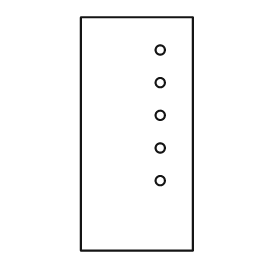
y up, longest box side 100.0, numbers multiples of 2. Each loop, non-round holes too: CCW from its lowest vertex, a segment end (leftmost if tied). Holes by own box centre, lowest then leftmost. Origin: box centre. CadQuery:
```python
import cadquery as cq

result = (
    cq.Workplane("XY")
    .moveTo(-24.0, -50.0)
    .lineTo(24.0, -50.0)
    .lineTo(24.0, 50.0)
    .lineTo(-24.0, 50.0)
    .close()
    .moveTo(10.0, -20.0)
    .circle(2.0)
    .moveTo(10.0, -6.0)
    .circle(2.0)
    .moveTo(10.0, 8.0)
    .circle(2.0)
    .moveTo(10.0, 22.0)
    .circle(2.0)
    .moveTo(10.0, 36.0)
    .circle(2.0)
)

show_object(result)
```